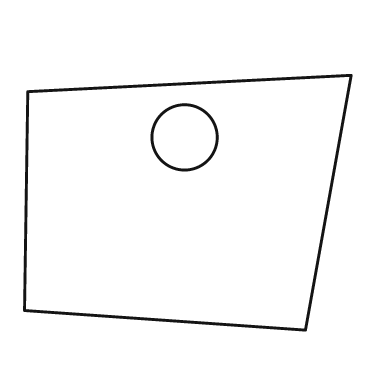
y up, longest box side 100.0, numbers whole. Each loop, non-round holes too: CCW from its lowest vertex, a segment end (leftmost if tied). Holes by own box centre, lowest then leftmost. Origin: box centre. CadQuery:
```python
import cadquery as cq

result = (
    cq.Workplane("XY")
    .moveTo(36.0, -39.0)
    .lineTo(50.0, 39.0)
    .lineTo(-49.0, 34.0)
    .lineTo(-50.0, -33.0)
    .close()
    .moveTo(-1.0, 20.0)
    .circle(10.0)
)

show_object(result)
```